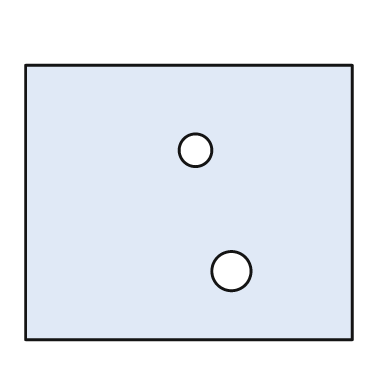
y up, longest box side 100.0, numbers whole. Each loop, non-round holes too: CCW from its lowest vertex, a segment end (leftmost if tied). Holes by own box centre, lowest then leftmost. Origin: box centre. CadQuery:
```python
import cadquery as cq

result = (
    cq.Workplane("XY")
    .moveTo(-50.0, -42.0)
    .lineTo(50.0, -42.0)
    .lineTo(50.0, 42.0)
    .lineTo(-50.0, 42.0)
    .close()
    .moveTo(13.0, -21.0)
    .circle(6.0)
    .moveTo(2.0, 16.0)
    .circle(5.0)
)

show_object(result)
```